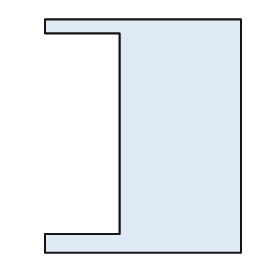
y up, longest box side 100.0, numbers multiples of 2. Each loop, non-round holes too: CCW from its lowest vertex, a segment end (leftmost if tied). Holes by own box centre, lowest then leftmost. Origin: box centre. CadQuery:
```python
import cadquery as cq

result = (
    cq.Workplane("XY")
    .moveTo(-42.0, -50.0)
    .lineTo(42.0, -50.0)
    .lineTo(42.0, 50.0)
    .lineTo(-42.0, 50.0)
    .lineTo(-42.0, 44.0)
    .lineTo(-10.0, 44.0)
    .lineTo(-10.0, -42.0)
    .lineTo(-42.0, -42.0)
    .close()
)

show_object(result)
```